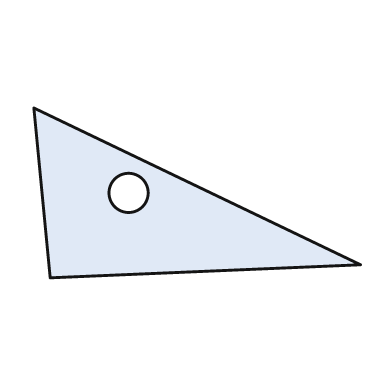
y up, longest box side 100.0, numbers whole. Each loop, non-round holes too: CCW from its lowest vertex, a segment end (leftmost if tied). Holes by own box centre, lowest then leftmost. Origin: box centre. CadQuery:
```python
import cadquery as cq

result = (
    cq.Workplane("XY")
    .moveTo(-45.0, -26.0)
    .lineTo(50.0, -22.0)
    .lineTo(-50.0, 26.0)
    .close()
    .moveTo(-21.0, 0.0)
    .circle(6.0)
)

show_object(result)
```